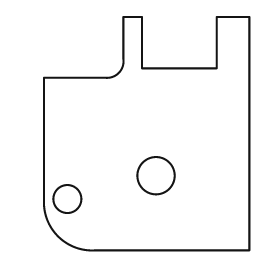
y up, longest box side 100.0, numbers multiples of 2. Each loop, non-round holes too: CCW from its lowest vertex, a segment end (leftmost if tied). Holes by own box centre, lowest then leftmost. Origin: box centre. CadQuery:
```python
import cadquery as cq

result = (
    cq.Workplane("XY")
    .moveTo(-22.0, -50.0)
    .lineTo(44.0, -50.0)
    .lineTo(44.0, 50.0)
    .lineTo(30.0, 50.0)
    .lineTo(30.0, 28.0)
    .lineTo(-2.0, 28.0)
    .lineTo(-2.0, 50.0)
    .lineTo(-10.0, 50.0)
    .lineTo(-10.0, 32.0)
    .threePointArc((-12.0, 26.0), (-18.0, 24.0))
    .lineTo(-44.0, 24.0)
    .lineTo(-44.0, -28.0)
    .threePointArc((-38.0, -44.0), (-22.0, -50.0))
    .close()
    .moveTo(-34.0, -28.0)
    .circle(6.0)
    .moveTo(4.0, -18.0)
    .circle(8.0)
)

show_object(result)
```